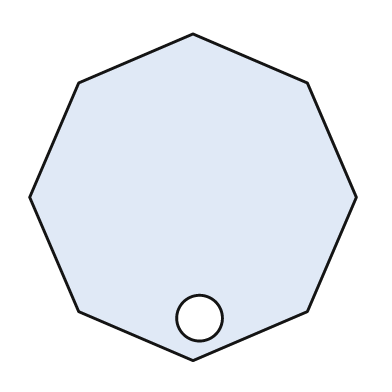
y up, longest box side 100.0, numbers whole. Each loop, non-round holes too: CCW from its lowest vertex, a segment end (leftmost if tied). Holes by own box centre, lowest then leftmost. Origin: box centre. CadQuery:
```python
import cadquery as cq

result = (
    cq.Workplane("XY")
    .moveTo(0.0, -50.0)
    .lineTo(35.0, -35.0)
    .lineTo(50.0, 0.0)
    .lineTo(35.0, 35.0)
    .lineTo(0.0, 50.0)
    .lineTo(-35.0, 35.0)
    .lineTo(-50.0, 0.0)
    .lineTo(-35.0, -35.0)
    .close()
    .moveTo(2.0, -37.0)
    .circle(7.0)
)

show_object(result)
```